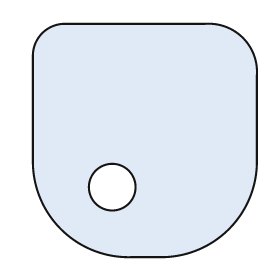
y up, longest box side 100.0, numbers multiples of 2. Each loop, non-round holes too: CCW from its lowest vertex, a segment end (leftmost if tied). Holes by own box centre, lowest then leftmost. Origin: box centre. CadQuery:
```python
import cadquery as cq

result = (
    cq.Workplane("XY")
    .moveTo(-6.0, -50.0)
    .lineTo(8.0, -50.0)
    .threePointArc((36.0, -38.0), (48.0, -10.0))
    .lineTo(48.0, 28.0)
    .threePointArc((42.0, 44.0), (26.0, 50.0))
    .lineTo(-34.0, 50.0)
    .threePointArc((-44.0, 46.0), (-48.0, 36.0))
    .lineTo(-48.0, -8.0)
    .threePointArc((-36.0, -38.0), (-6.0, -50.0))
    .close()
    .moveTo(-14.0, -20.0)
    .circle(10.0)
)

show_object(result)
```